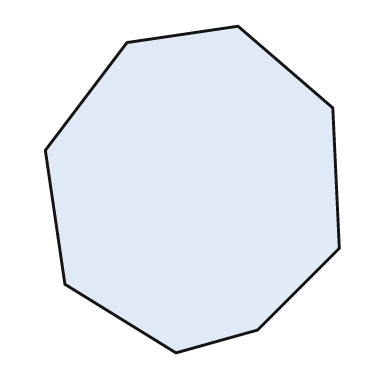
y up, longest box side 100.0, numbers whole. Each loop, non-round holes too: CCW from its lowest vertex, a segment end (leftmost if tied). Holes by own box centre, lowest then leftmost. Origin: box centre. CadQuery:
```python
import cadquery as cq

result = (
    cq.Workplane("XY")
    .moveTo(-5.0, -50.0)
    .lineTo(20.0, -43.0)
    .lineTo(45.0, -18.0)
    .lineTo(43.0, 25.0)
    .lineTo(14.0, 50.0)
    .lineTo(-20.0, 45.0)
    .lineTo(-45.0, 12.0)
    .lineTo(-39.0, -29.0)
    .close()
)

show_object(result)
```